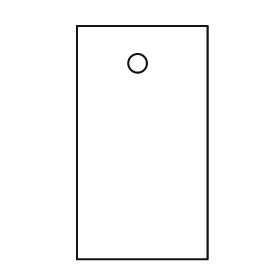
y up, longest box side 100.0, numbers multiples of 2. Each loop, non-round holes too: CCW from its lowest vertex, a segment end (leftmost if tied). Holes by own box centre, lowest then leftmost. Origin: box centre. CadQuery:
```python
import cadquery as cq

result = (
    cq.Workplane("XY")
    .moveTo(-28.0, -50.0)
    .lineTo(28.0, -50.0)
    .lineTo(28.0, 50.0)
    .lineTo(-28.0, 50.0)
    .close()
    .moveTo(-2.0, 34.0)
    .circle(4.0)
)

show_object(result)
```